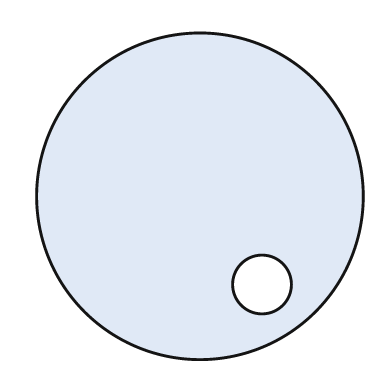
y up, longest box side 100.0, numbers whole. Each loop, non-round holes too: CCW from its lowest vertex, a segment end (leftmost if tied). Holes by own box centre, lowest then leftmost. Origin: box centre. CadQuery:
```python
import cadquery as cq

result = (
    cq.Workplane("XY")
    .moveTo(0.0, 0.0)
    .circle(50.0)
    .moveTo(19.0, -27.0)
    .circle(9.0)
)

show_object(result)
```